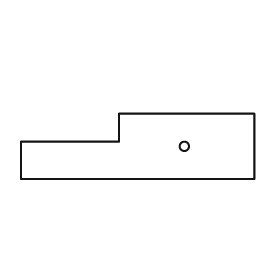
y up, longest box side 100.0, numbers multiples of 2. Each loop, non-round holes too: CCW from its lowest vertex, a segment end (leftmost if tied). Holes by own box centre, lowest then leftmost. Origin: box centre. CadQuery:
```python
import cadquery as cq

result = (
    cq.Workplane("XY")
    .moveTo(-50.0, -14.0)
    .lineTo(50.0, -14.0)
    .lineTo(50.0, 14.0)
    .lineTo(-8.0, 14.0)
    .lineTo(-8.0, 2.0)
    .lineTo(-50.0, 2.0)
    .close()
    .moveTo(20.0, 0.0)
    .circle(2.0)
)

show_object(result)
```